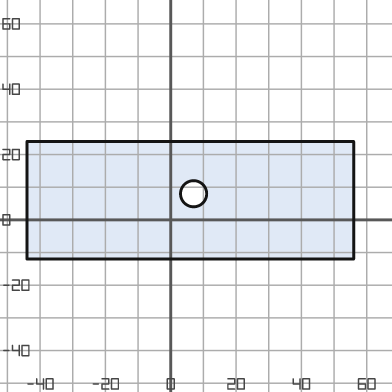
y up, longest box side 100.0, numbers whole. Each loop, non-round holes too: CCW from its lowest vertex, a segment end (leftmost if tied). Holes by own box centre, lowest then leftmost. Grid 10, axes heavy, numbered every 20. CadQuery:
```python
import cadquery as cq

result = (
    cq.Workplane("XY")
    .moveTo(-44.0, -12.0)
    .lineTo(56.0, -12.0)
    .lineTo(56.0, 24.0)
    .lineTo(-44.0, 24.0)
    .close()
    .moveTo(7.0, 8.0)
    .circle(4.0)
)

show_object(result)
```